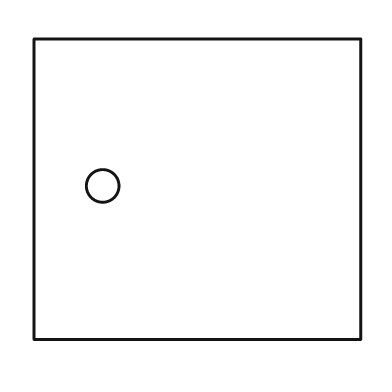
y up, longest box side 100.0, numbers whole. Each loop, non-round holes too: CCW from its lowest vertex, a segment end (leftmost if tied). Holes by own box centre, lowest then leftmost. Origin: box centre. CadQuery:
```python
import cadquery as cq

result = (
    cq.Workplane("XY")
    .moveTo(-50.0, -46.0)
    .lineTo(50.0, -46.0)
    .lineTo(50.0, 46.0)
    .lineTo(-50.0, 46.0)
    .close()
    .moveTo(-29.0, 1.0)
    .circle(5.0)
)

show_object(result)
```